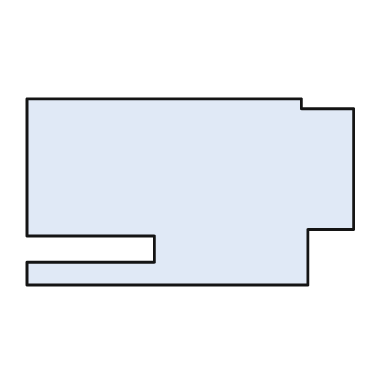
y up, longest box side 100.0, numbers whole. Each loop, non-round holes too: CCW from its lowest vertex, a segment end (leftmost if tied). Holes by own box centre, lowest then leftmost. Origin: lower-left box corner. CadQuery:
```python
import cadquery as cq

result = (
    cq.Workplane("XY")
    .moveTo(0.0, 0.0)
    .lineTo(86.0, 0.0)
    .lineTo(86.0, 17.0)
    .lineTo(100.0, 17.0)
    .lineTo(100.0, 54.0)
    .lineTo(84.0, 54.0)
    .lineTo(84.0, 57.0)
    .lineTo(0.0, 57.0)
    .lineTo(0.0, 15.0)
    .lineTo(39.0, 15.0)
    .lineTo(39.0, 7.0)
    .lineTo(0.0, 7.0)
    .close()
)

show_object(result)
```